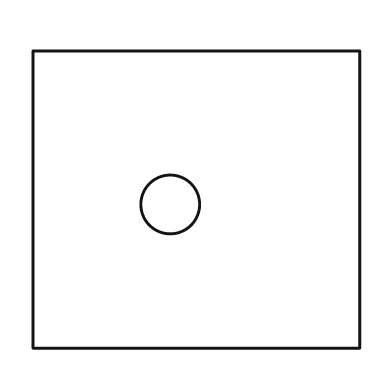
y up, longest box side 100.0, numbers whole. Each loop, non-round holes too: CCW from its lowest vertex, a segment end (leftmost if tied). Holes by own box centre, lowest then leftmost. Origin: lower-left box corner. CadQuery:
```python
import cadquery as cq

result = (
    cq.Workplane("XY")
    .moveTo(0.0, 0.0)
    .lineTo(100.0, 0.0)
    .lineTo(100.0, 91.0)
    .lineTo(0.0, 91.0)
    .close()
    .moveTo(42.0, 44.0)
    .circle(9.0)
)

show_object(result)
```